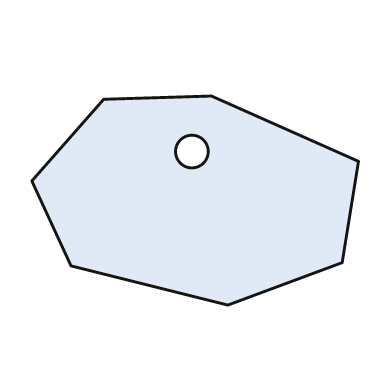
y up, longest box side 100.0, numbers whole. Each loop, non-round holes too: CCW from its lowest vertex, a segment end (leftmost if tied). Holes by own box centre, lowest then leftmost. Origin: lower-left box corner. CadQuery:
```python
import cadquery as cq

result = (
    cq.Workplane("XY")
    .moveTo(60.0, 0.0)
    .lineTo(95.0, 13.0)
    .lineTo(100.0, 44.0)
    .lineTo(55.0, 64.0)
    .lineTo(22.0, 63.0)
    .lineTo(0.0, 38.0)
    .lineTo(12.0, 12.0)
    .close()
    .moveTo(49.0, 47.0)
    .circle(5.0)
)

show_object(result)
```